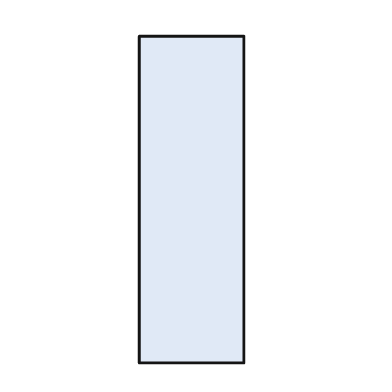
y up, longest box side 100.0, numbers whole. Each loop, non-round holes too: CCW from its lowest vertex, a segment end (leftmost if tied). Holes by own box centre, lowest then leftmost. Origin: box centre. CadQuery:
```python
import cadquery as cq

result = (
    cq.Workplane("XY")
    .moveTo(-16.0, -50.0)
    .lineTo(16.0, -50.0)
    .lineTo(16.0, 50.0)
    .lineTo(-16.0, 50.0)
    .close()
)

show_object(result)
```